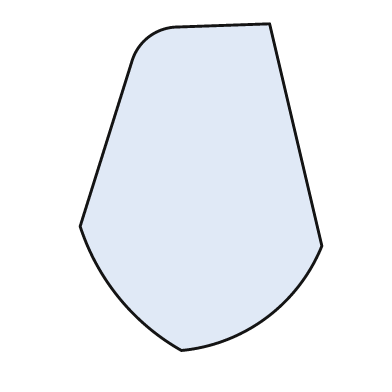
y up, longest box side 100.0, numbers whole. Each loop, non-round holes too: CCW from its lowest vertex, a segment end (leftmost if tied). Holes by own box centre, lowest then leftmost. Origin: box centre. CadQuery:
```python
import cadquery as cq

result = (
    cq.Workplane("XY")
    .moveTo(-6.0, -50.0)
    .threePointArc((20.0, -40.0), (37.0, -18.0))
    .lineTo(21.0, 50.0)
    .lineTo(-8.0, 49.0)
    .threePointArc((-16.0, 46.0), (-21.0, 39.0))
    .lineTo(-37.0, -12.0)
    .threePointArc((-25.0, -34.0), (-6.0, -50.0))
    .close()
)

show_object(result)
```